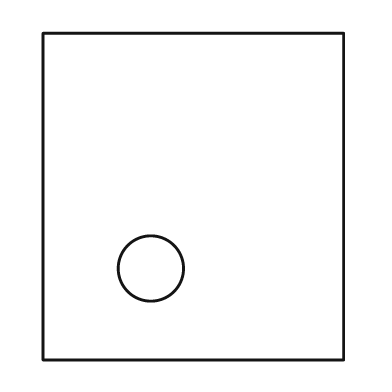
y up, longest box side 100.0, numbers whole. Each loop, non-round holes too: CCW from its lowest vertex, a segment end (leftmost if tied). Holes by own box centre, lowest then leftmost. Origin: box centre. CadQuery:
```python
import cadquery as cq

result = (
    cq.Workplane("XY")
    .moveTo(-46.0, -50.0)
    .lineTo(46.0, -50.0)
    .lineTo(46.0, 50.0)
    .lineTo(-46.0, 50.0)
    .close()
    .moveTo(-13.0, -22.0)
    .circle(10.0)
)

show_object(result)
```